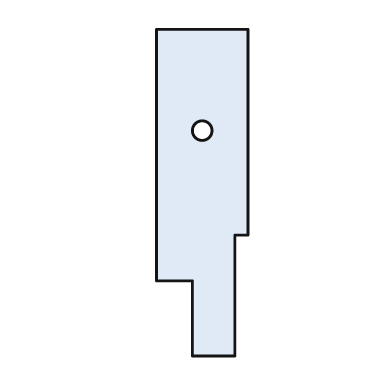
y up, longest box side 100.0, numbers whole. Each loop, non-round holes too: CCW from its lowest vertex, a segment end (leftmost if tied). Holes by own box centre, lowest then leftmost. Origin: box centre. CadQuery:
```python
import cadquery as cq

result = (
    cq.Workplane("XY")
    .moveTo(-3.0, -50.0)
    .lineTo(10.0, -50.0)
    .lineTo(10.0, -13.0)
    .lineTo(14.0, -13.0)
    .lineTo(14.0, 50.0)
    .lineTo(-14.0, 50.0)
    .lineTo(-14.0, -27.0)
    .lineTo(-3.0, -27.0)
    .close()
    .moveTo(0.0, 19.0)
    .circle(3.0)
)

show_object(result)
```